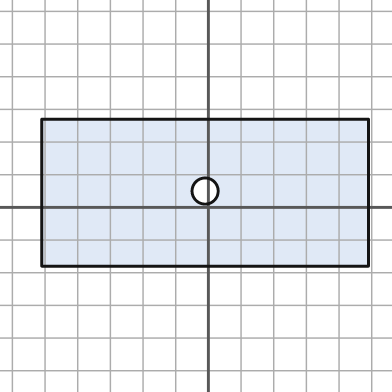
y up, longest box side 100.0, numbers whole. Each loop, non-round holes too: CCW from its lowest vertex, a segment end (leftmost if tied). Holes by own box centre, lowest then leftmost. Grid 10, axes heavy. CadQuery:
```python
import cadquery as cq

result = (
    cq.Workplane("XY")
    .moveTo(-51.0, -18.0)
    .lineTo(49.0, -18.0)
    .lineTo(49.0, 27.0)
    .lineTo(-51.0, 27.0)
    .close()
    .moveTo(-1.0, 5.0)
    .circle(4.0)
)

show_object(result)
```